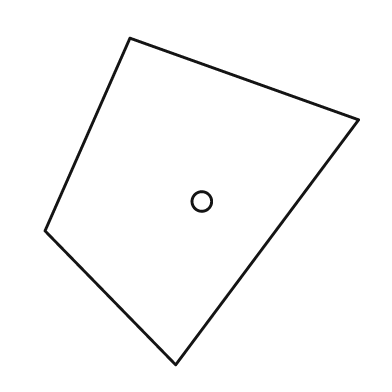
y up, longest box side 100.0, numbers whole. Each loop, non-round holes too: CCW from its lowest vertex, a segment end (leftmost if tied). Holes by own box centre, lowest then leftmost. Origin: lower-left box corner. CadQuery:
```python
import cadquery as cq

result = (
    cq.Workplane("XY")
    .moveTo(40.0, 0.0)
    .lineTo(96.0, 75.0)
    .lineTo(26.0, 100.0)
    .lineTo(0.0, 41.0)
    .close()
    .moveTo(48.0, 50.0)
    .circle(3.0)
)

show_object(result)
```